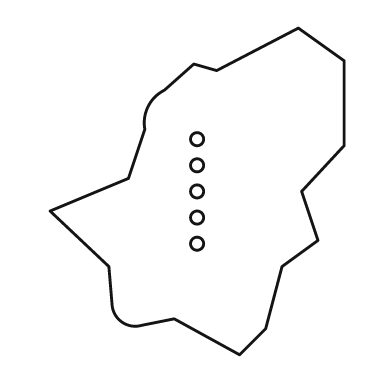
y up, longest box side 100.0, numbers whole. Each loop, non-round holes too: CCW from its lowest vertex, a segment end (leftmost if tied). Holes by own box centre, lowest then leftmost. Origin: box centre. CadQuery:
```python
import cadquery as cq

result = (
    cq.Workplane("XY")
    .moveTo(13.0, -50.0)
    .lineTo(21.0, -42.0)
    .lineTo(26.0, -23.0)
    .lineTo(37.0, -15.0)
    .lineTo(32.0, 0.0)
    .lineTo(45.0, 14.0)
    .lineTo(45.0, 40.0)
    .lineTo(31.0, 50.0)
    .lineTo(6.0, 37.0)
    .lineTo(-1.0, 39.0)
    .lineTo(-10.0, 31.0)
    .threePointArc((-15.0, 26.0), (-16.0, 19.0))
    .lineTo(-21.0, 4.0)
    .lineTo(-45.0, -6.0)
    .lineTo(-27.0, -23.0)
    .lineTo(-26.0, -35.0)
    .threePointArc((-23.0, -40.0), (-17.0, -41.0))
    .lineTo(-7.0, -39.0)
    .close()
    .moveTo(0.0, -16.0)
    .circle(2.0)
    .moveTo(0.0, -8.0)
    .circle(2.0)
    .moveTo(0.0, 0.0)
    .circle(2.0)
    .moveTo(0.0, 8.0)
    .circle(2.0)
    .moveTo(0.0, 16.0)
    .circle(2.0)
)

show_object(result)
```